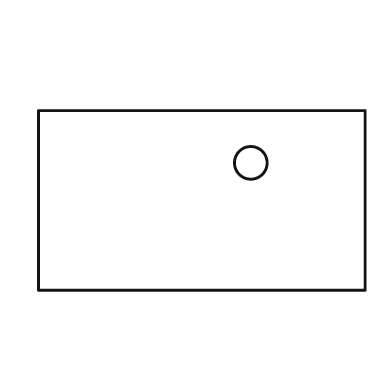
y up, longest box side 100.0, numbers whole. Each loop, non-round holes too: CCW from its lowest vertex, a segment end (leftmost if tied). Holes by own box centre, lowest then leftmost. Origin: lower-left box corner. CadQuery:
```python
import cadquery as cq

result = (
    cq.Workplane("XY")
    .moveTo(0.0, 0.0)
    .lineTo(100.0, 0.0)
    .lineTo(100.0, 55.0)
    .lineTo(0.0, 55.0)
    .close()
    .moveTo(65.0, 39.0)
    .circle(5.0)
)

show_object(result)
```